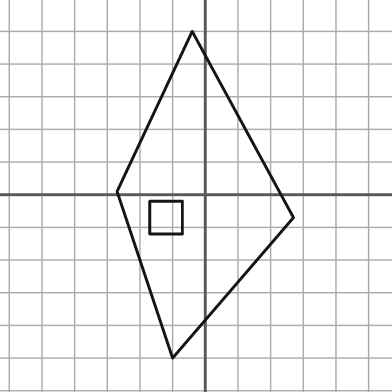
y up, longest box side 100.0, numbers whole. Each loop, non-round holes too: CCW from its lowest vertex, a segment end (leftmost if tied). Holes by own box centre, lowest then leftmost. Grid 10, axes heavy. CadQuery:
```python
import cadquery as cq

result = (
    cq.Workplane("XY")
    .moveTo(-10.0, -50.0)
    .lineTo(27.0, -7.0)
    .lineTo(-4.0, 50.0)
    .lineTo(-27.0, 1.0)
    .close()
    .moveTo(-17.0, -12.0)
    .lineTo(-7.0, -12.0)
    .lineTo(-7.0, -2.0)
    .lineTo(-17.0, -2.0)
    .close()
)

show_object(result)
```